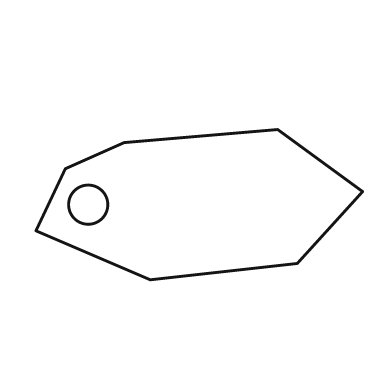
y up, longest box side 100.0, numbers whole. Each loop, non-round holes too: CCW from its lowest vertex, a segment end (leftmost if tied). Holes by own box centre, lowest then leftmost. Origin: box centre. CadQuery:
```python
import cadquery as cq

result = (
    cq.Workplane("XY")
    .moveTo(-15.0, -23.0)
    .lineTo(30.0, -18.0)
    .lineTo(50.0, 4.0)
    .lineTo(24.0, 23.0)
    .lineTo(-23.0, 19.0)
    .lineTo(-41.0, 11.0)
    .lineTo(-50.0, -8.0)
    .close()
    .moveTo(-34.0, 0.0)
    .circle(6.0)
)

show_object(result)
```